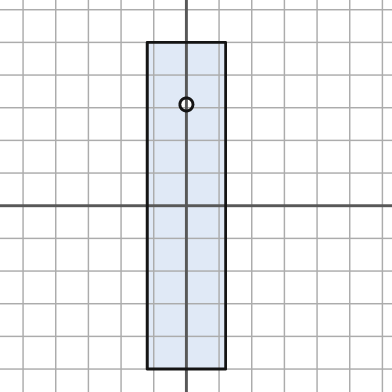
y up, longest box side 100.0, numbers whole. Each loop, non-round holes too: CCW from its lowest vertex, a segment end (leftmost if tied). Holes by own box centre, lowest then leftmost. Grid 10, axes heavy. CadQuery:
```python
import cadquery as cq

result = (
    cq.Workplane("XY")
    .moveTo(-12.0, -50.0)
    .lineTo(12.0, -50.0)
    .lineTo(12.0, 50.0)
    .lineTo(-12.0, 50.0)
    .close()
    .moveTo(0.0, 31.0)
    .circle(2.0)
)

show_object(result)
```